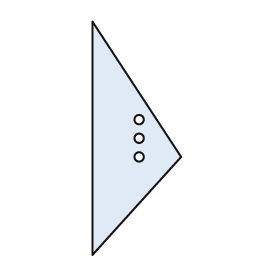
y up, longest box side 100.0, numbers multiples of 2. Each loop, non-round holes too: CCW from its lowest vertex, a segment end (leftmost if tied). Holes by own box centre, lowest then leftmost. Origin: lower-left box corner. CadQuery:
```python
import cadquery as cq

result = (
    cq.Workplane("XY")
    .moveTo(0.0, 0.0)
    .lineTo(38.0, 42.0)
    .lineTo(0.0, 100.0)
    .close()
    .moveTo(20.0, 42.0)
    .circle(2.0)
    .moveTo(20.0, 50.0)
    .circle(2.0)
    .moveTo(20.0, 58.0)
    .circle(2.0)
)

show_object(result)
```